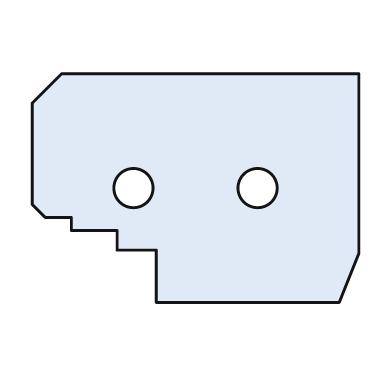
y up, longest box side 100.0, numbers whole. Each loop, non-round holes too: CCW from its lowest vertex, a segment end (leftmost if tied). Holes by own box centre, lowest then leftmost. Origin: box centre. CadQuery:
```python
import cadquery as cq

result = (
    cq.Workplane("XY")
    .moveTo(-12.0, -35.0)
    .lineTo(44.0, -35.0)
    .lineTo(50.0, -20.0)
    .lineTo(50.0, 35.0)
    .lineTo(-41.0, 35.0)
    .lineTo(-50.0, 26.0)
    .lineTo(-50.0, -5.0)
    .lineTo(-46.0, -9.0)
    .lineTo(-38.0, -9.0)
    .lineTo(-38.0, -13.0)
    .lineTo(-24.0, -13.0)
    .lineTo(-24.0, -19.0)
    .lineTo(-12.0, -19.0)
    .close()
    .moveTo(-19.0, 0.0)
    .circle(6.0)
    .moveTo(19.0, 0.0)
    .circle(6.0)
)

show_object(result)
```